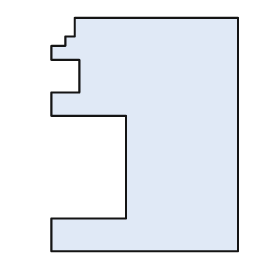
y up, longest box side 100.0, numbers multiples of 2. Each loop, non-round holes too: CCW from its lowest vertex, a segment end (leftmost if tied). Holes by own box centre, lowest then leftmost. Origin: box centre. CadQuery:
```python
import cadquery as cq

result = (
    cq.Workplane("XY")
    .moveTo(-40.0, -50.0)
    .lineTo(40.0, -50.0)
    .lineTo(40.0, 50.0)
    .lineTo(-30.0, 50.0)
    .lineTo(-30.0, 42.0)
    .lineTo(-34.0, 42.0)
    .lineTo(-34.0, 38.0)
    .lineTo(-40.0, 38.0)
    .lineTo(-40.0, 32.0)
    .lineTo(-28.0, 32.0)
    .lineTo(-28.0, 18.0)
    .lineTo(-40.0, 18.0)
    .lineTo(-40.0, 8.0)
    .lineTo(-8.0, 8.0)
    .lineTo(-8.0, -36.0)
    .lineTo(-40.0, -36.0)
    .close()
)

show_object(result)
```